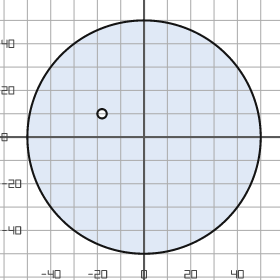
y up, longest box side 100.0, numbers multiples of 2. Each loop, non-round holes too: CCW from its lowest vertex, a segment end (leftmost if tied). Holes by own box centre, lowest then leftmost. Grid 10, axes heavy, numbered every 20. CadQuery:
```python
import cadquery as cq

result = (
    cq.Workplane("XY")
    .moveTo(0.0, 0.0)
    .circle(50.0)
    .moveTo(-18.0, 10.0)
    .circle(2.0)
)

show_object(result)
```